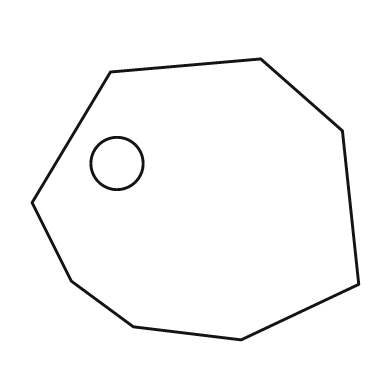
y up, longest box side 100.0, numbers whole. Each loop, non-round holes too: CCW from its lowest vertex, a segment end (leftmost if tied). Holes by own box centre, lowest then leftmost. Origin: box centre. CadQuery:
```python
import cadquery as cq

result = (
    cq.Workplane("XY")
    .moveTo(14.0, -43.0)
    .lineTo(50.0, -26.0)
    .lineTo(45.0, 21.0)
    .lineTo(20.0, 43.0)
    .lineTo(-26.0, 39.0)
    .lineTo(-50.0, -1.0)
    .lineTo(-38.0, -25.0)
    .lineTo(-19.0, -39.0)
    .close()
    .moveTo(-24.0, 11.0)
    .circle(8.0)
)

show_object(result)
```